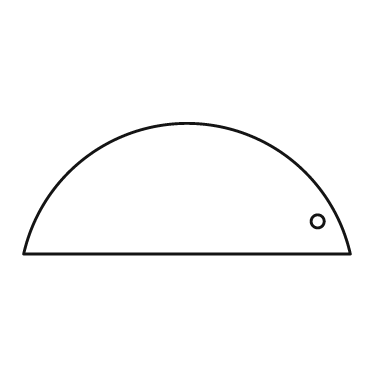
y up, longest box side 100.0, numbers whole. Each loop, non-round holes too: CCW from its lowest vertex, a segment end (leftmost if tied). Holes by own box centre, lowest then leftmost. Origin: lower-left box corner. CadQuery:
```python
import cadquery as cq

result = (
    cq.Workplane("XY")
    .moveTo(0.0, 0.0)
    .lineTo(100.0, 0.0)
    .threePointArc((50.0, 40.0), (0.0, 0.0))
    .close()
    .moveTo(90.0, 10.0)
    .circle(2.0)
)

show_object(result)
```